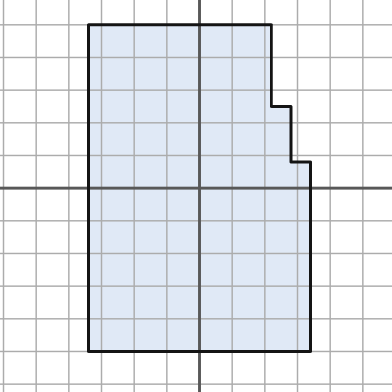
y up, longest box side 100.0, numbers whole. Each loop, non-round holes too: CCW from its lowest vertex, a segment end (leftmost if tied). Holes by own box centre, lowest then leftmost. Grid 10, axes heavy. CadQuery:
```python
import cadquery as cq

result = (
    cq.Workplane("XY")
    .moveTo(-34.0, -50.0)
    .lineTo(34.0, -50.0)
    .lineTo(34.0, 8.0)
    .lineTo(28.0, 8.0)
    .lineTo(28.0, 25.0)
    .lineTo(22.0, 25.0)
    .lineTo(22.0, 50.0)
    .lineTo(-34.0, 50.0)
    .close()
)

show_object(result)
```